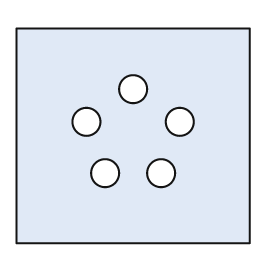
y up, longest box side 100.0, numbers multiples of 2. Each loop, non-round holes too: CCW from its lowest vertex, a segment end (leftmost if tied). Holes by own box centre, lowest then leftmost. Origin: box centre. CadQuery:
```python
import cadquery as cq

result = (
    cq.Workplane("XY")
    .moveTo(-50.0, -46.0)
    .lineTo(50.0, -46.0)
    .lineTo(50.0, 46.0)
    .lineTo(-50.0, 46.0)
    .close()
    .moveTo(-12.0, -16.0)
    .circle(6.0)
    .moveTo(12.0, -16.0)
    .circle(6.0)
    .moveTo(-20.0, 6.0)
    .circle(6.0)
    .moveTo(20.0, 6.0)
    .circle(6.0)
    .moveTo(0.0, 20.0)
    .circle(6.0)
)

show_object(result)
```